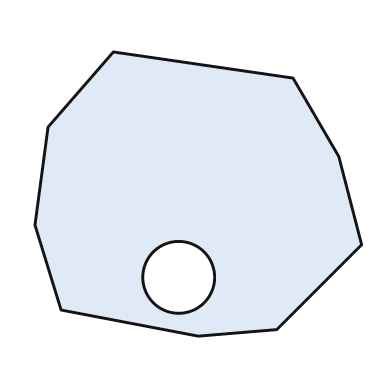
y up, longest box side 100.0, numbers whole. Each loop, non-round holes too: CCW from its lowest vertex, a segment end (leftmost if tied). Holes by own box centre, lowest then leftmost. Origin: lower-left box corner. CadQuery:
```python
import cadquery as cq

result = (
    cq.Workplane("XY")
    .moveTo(50.0, 0.0)
    .lineTo(74.0, 2.0)
    .lineTo(100.0, 28.0)
    .lineTo(93.0, 55.0)
    .lineTo(79.0, 79.0)
    .lineTo(24.0, 87.0)
    .lineTo(4.0, 64.0)
    .lineTo(0.0, 34.0)
    .lineTo(8.0, 8.0)
    .close()
    .moveTo(44.0, 18.0)
    .circle(11.0)
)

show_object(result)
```